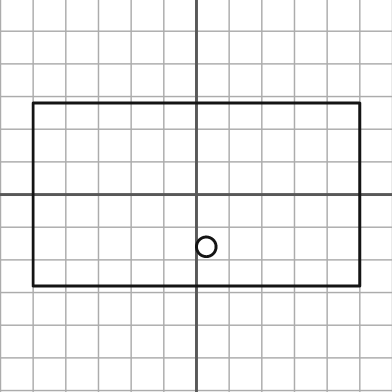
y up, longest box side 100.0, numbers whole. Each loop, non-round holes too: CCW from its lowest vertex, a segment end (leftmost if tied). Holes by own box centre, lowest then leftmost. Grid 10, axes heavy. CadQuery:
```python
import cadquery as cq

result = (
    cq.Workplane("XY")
    .moveTo(-50.0, -28.0)
    .lineTo(50.0, -28.0)
    .lineTo(50.0, 28.0)
    .lineTo(-50.0, 28.0)
    .close()
    .moveTo(3.0, -16.0)
    .circle(3.0)
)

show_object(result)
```